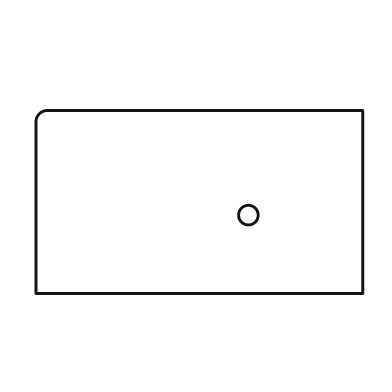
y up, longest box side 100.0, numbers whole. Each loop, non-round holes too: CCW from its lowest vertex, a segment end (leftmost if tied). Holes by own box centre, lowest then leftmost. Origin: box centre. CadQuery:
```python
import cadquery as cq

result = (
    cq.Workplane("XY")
    .moveTo(-50.0, -28.0)
    .lineTo(50.0, -28.0)
    .lineTo(50.0, 28.0)
    .lineTo(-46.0, 28.0)
    .threePointArc((-49.0, 27.0), (-50.0, 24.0))
    .close()
    .moveTo(15.0, -4.0)
    .circle(3.0)
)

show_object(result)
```